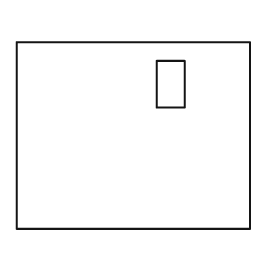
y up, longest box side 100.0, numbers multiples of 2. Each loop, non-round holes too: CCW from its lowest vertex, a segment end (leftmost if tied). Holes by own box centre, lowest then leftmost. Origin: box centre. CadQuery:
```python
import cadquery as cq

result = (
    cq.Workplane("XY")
    .moveTo(-50.0, -40.0)
    .lineTo(50.0, -40.0)
    .lineTo(50.0, 40.0)
    .lineTo(-50.0, 40.0)
    .close()
    .moveTo(10.0, 12.0)
    .lineTo(22.0, 12.0)
    .lineTo(22.0, 32.0)
    .lineTo(10.0, 32.0)
    .close()
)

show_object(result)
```